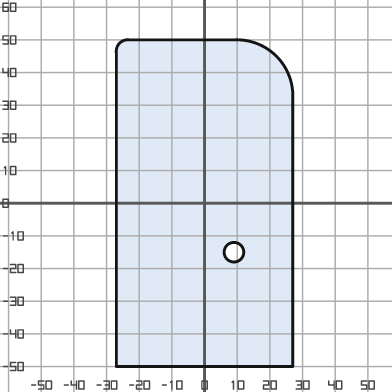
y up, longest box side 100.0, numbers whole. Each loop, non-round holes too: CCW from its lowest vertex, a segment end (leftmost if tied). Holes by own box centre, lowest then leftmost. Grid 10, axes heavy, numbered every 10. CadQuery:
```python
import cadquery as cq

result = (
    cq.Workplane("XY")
    .moveTo(-27.0, -50.0)
    .lineTo(27.0, -50.0)
    .lineTo(27.0, 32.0)
    .threePointArc((22.0, 45.0), (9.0, 50.0))
    .lineTo(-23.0, 50.0)
    .threePointArc((-26.0, 49.0), (-27.0, 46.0))
    .close()
    .moveTo(9.0, -15.0)
    .circle(3.0)
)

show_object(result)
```